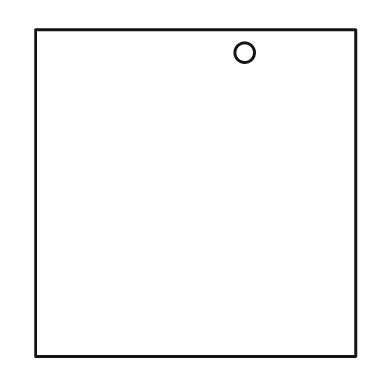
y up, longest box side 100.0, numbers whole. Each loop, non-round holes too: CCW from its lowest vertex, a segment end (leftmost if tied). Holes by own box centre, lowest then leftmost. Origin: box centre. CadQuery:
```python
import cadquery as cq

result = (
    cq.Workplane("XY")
    .moveTo(-49.0, -50.0)
    .lineTo(49.0, -50.0)
    .lineTo(49.0, 50.0)
    .lineTo(-49.0, 50.0)
    .close()
    .moveTo(15.0, 43.0)
    .circle(3.0)
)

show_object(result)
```